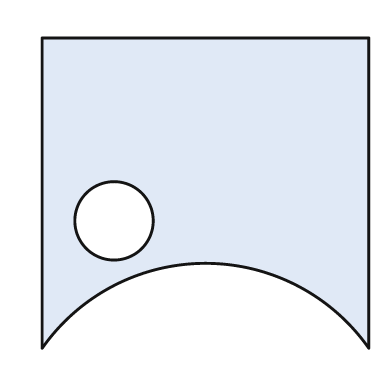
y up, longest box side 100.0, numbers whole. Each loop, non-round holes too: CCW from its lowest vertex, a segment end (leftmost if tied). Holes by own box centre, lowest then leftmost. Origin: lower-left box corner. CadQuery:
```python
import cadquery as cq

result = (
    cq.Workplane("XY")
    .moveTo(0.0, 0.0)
    .threePointArc((50.0, 26.0), (100.0, 0.0))
    .lineTo(100.0, 95.0)
    .lineTo(0.0, 95.0)
    .close()
    .moveTo(22.0, 39.0)
    .circle(12.0)
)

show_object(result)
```